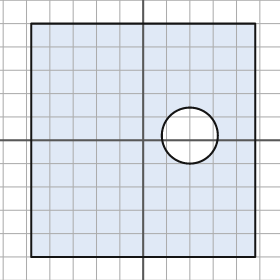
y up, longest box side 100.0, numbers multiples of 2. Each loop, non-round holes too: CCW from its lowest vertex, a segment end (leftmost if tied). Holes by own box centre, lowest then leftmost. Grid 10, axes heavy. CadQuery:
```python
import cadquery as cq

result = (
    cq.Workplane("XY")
    .moveTo(-48.0, -50.0)
    .lineTo(48.0, -50.0)
    .lineTo(48.0, 50.0)
    .lineTo(-48.0, 50.0)
    .close()
    .moveTo(20.0, 2.0)
    .circle(12.0)
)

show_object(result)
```